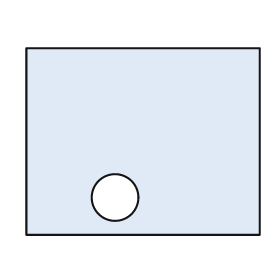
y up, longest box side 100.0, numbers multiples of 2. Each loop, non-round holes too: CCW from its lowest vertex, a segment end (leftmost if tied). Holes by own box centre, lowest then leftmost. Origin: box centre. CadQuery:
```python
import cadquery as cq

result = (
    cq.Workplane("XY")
    .moveTo(-50.0, -40.0)
    .lineTo(50.0, -40.0)
    .lineTo(50.0, 40.0)
    .lineTo(-50.0, 40.0)
    .close()
    .moveTo(-12.0, -24.0)
    .circle(10.0)
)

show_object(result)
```